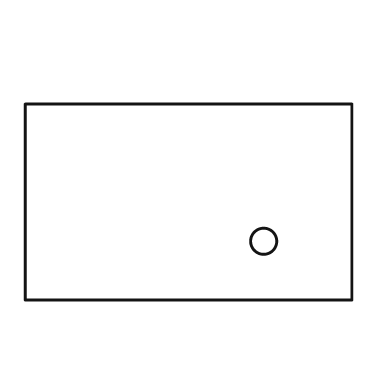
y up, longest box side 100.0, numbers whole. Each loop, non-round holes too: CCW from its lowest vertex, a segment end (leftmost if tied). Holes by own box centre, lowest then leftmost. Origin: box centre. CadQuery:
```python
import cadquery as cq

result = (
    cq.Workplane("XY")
    .moveTo(-50.0, -30.0)
    .lineTo(50.0, -30.0)
    .lineTo(50.0, 30.0)
    .lineTo(-50.0, 30.0)
    .close()
    .moveTo(23.0, -12.0)
    .circle(4.0)
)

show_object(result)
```